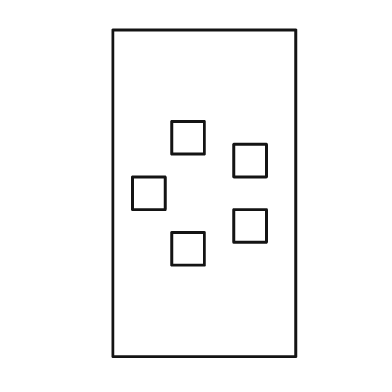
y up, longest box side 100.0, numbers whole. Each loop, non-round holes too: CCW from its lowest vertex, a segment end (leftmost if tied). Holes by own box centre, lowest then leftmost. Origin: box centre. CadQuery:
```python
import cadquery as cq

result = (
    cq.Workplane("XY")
    .moveTo(-28.0, -50.0)
    .lineTo(28.0, -50.0)
    .lineTo(28.0, 50.0)
    .lineTo(-28.0, 50.0)
    .close()
    .moveTo(-10.0, -22.0)
    .lineTo(0.0, -22.0)
    .lineTo(0.0, -12.0)
    .lineTo(-10.0, -12.0)
    .close()
    .moveTo(9.0, -15.0)
    .lineTo(19.0, -15.0)
    .lineTo(19.0, -5.0)
    .lineTo(9.0, -5.0)
    .close()
    .moveTo(-22.0, -5.0)
    .lineTo(-12.0, -5.0)
    .lineTo(-12.0, 5.0)
    .lineTo(-22.0, 5.0)
    .close()
    .moveTo(9.0, 5.0)
    .lineTo(19.0, 5.0)
    .lineTo(19.0, 15.0)
    .lineTo(9.0, 15.0)
    .close()
    .moveTo(-10.0, 12.0)
    .lineTo(0.0, 12.0)
    .lineTo(0.0, 22.0)
    .lineTo(-10.0, 22.0)
    .close()
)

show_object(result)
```